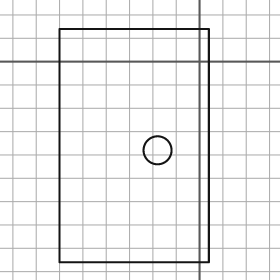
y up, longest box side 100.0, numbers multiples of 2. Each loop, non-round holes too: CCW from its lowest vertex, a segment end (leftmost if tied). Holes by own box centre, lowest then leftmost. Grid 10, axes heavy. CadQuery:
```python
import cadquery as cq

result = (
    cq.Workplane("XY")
    .moveTo(-60.0, -86.0)
    .lineTo(4.0, -86.0)
    .lineTo(4.0, 14.0)
    .lineTo(-60.0, 14.0)
    .close()
    .moveTo(-18.0, -38.0)
    .circle(6.0)
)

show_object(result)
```